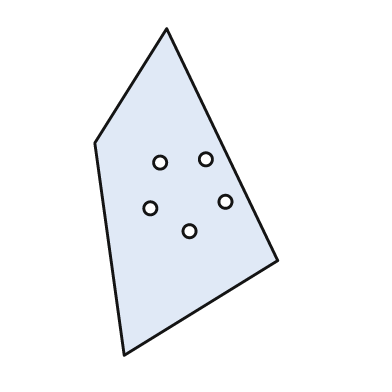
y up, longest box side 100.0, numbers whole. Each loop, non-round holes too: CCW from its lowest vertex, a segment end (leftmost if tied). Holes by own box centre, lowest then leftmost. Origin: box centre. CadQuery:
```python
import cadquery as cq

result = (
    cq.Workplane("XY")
    .moveTo(-19.0, -50.0)
    .lineTo(28.0, -21.0)
    .lineTo(-6.0, 50.0)
    .lineTo(-28.0, 15.0)
    .close()
    .moveTo(1.0, -12.0)
    .circle(2.0)
    .moveTo(-11.0, -5.0)
    .circle(2.0)
    .moveTo(12.0, -3.0)
    .circle(2.0)
    .moveTo(-8.0, 9.0)
    .circle(2.0)
    .moveTo(6.0, 10.0)
    .circle(2.0)
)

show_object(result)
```